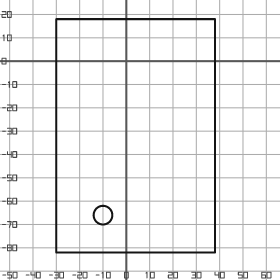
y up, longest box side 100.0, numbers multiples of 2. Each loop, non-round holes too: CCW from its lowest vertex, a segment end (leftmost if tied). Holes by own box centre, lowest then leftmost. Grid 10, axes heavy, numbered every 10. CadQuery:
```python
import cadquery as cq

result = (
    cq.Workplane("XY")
    .moveTo(-30.0, -82.0)
    .lineTo(38.0, -82.0)
    .lineTo(38.0, 18.0)
    .lineTo(-30.0, 18.0)
    .close()
    .moveTo(-10.0, -66.0)
    .circle(4.0)
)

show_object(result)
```